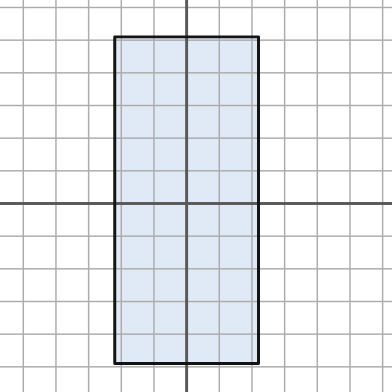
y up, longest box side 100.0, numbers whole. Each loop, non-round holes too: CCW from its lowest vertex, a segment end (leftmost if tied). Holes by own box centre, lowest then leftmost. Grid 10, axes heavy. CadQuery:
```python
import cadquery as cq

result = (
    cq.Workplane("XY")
    .moveTo(-22.0, -49.0)
    .lineTo(22.0, -49.0)
    .lineTo(22.0, 51.0)
    .lineTo(-22.0, 51.0)
    .close()
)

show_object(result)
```